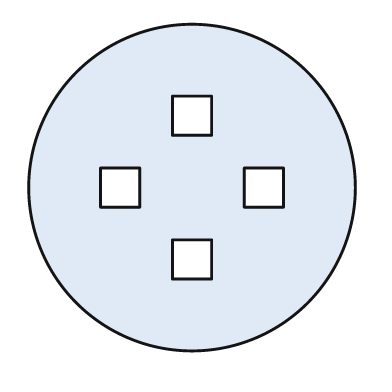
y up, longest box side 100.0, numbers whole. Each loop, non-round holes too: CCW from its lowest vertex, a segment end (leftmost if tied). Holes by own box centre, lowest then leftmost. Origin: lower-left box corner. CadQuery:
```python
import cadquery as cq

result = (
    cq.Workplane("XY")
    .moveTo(50.0, 50.0)
    .circle(50.0)
    .moveTo(44.0, 22.0)
    .lineTo(56.0, 22.0)
    .lineTo(56.0, 34.0)
    .lineTo(44.0, 34.0)
    .close()
    .moveTo(22.0, 44.0)
    .lineTo(34.0, 44.0)
    .lineTo(34.0, 56.0)
    .lineTo(22.0, 56.0)
    .close()
    .moveTo(66.0, 44.0)
    .lineTo(78.0, 44.0)
    .lineTo(78.0, 56.0)
    .lineTo(66.0, 56.0)
    .close()
    .moveTo(44.0, 66.0)
    .lineTo(56.0, 66.0)
    .lineTo(56.0, 78.0)
    .lineTo(44.0, 78.0)
    .close()
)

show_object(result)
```